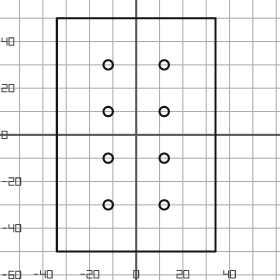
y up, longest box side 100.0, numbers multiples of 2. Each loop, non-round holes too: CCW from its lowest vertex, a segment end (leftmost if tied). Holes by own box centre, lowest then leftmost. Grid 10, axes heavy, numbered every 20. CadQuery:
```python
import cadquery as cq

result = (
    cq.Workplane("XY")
    .moveTo(-34.0, -50.0)
    .lineTo(34.0, -50.0)
    .lineTo(34.0, 50.0)
    .lineTo(-34.0, 50.0)
    .close()
    .moveTo(-12.0, -30.0)
    .circle(2.0)
    .moveTo(12.0, -30.0)
    .circle(2.0)
    .moveTo(-12.0, -10.0)
    .circle(2.0)
    .moveTo(12.0, -10.0)
    .circle(2.0)
    .moveTo(-12.0, 10.0)
    .circle(2.0)
    .moveTo(12.0, 10.0)
    .circle(2.0)
    .moveTo(-12.0, 30.0)
    .circle(2.0)
    .moveTo(12.0, 30.0)
    .circle(2.0)
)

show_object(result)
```